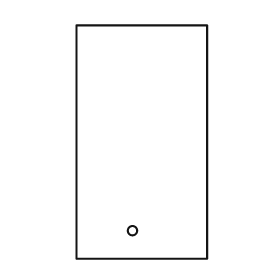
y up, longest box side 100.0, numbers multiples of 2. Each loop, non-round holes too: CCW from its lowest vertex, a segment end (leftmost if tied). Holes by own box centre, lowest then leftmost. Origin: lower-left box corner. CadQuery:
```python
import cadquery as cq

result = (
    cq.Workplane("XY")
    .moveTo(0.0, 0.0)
    .lineTo(56.0, 0.0)
    .lineTo(56.0, 100.0)
    .lineTo(0.0, 100.0)
    .close()
    .moveTo(24.0, 12.0)
    .circle(2.0)
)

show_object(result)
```